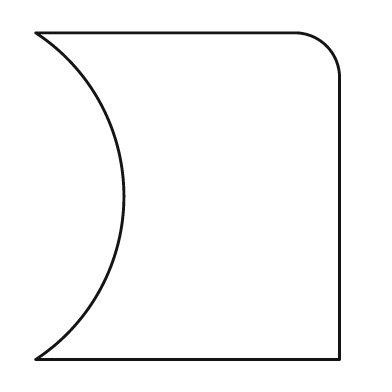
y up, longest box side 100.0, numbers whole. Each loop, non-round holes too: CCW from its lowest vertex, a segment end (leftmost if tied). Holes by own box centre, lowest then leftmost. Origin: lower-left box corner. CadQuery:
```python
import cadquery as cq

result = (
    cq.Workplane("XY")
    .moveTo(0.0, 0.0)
    .lineTo(93.0, 0.0)
    .lineTo(93.0, 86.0)
    .threePointArc((89.0, 96.0), (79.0, 100.0))
    .lineTo(0.0, 100.0)
    .threePointArc((27.0, 50.0), (0.0, 0.0))
    .close()
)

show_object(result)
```